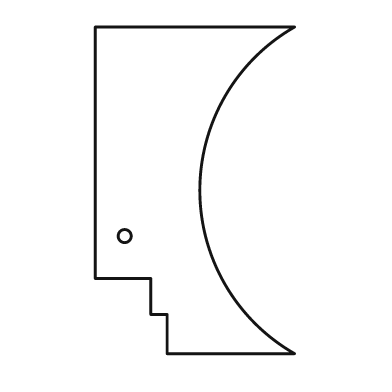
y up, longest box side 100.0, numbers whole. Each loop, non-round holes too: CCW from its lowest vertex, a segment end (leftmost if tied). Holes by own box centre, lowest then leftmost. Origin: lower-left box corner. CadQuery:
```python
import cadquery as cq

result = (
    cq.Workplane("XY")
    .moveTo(22.0, 0.0)
    .lineTo(61.0, 0.0)
    .threePointArc((32.0, 50.0), (61.0, 100.0))
    .lineTo(0.0, 100.0)
    .lineTo(0.0, 23.0)
    .lineTo(17.0, 23.0)
    .lineTo(17.0, 12.0)
    .lineTo(22.0, 12.0)
    .close()
    .moveTo(9.0, 36.0)
    .circle(2.0)
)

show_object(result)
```